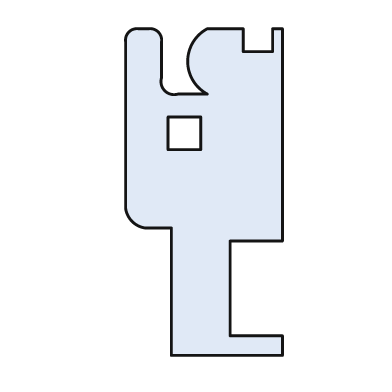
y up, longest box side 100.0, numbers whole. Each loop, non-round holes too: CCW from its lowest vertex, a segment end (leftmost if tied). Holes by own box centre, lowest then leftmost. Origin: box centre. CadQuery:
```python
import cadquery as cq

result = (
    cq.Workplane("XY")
    .moveTo(-10.0, -50.0)
    .lineTo(24.0, -50.0)
    .lineTo(24.0, -44.0)
    .lineTo(8.0, -44.0)
    .lineTo(8.0, -15.0)
    .lineTo(24.0, -15.0)
    .lineTo(24.0, 50.0)
    .lineTo(21.0, 50.0)
    .lineTo(21.0, 43.0)
    .lineTo(12.0, 43.0)
    .lineTo(12.0, 50.0)
    .lineTo(1.0, 50.0)
    .threePointArc((-5.0, 40.0), (1.0, 30.0))
    .lineTo(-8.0, 30.0)
    .threePointArc((-12.0, 31.0), (-13.0, 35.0))
    .lineTo(-13.0, 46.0)
    .threePointArc((-14.0, 49.0), (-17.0, 50.0))
    .lineTo(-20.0, 50.0)
    .threePointArc((-23.0, 49.0), (-24.0, 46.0))
    .lineTo(-24.0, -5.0)
    .threePointArc((-22.0, -9.0), (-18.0, -11.0))
    .lineTo(-10.0, -11.0)
    .close()
    .moveTo(-11.0, 13.0)
    .lineTo(-1.0, 13.0)
    .lineTo(-1.0, 23.0)
    .lineTo(-11.0, 23.0)
    .close()
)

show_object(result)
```